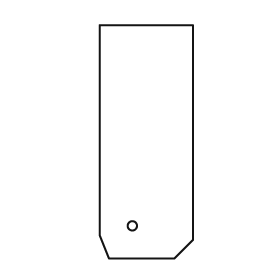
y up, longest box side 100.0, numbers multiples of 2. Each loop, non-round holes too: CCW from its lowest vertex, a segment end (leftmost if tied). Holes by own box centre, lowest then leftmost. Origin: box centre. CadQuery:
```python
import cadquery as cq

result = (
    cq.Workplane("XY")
    .moveTo(-16.0, -50.0)
    .lineTo(12.0, -50.0)
    .lineTo(20.0, -42.0)
    .lineTo(20.0, 50.0)
    .lineTo(-20.0, 50.0)
    .lineTo(-20.0, -40.0)
    .close()
    .moveTo(-6.0, -36.0)
    .circle(2.0)
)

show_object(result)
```